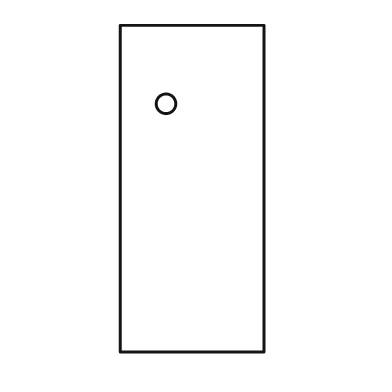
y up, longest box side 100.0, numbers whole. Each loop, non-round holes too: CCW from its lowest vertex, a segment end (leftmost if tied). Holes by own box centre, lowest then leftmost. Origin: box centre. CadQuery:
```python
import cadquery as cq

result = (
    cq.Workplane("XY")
    .moveTo(-22.0, -50.0)
    .lineTo(22.0, -50.0)
    .lineTo(22.0, 50.0)
    .lineTo(-22.0, 50.0)
    .close()
    .moveTo(-8.0, 26.0)
    .circle(3.0)
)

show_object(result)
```